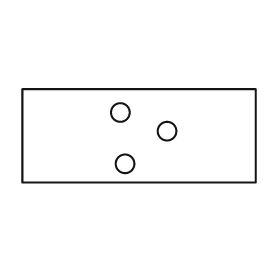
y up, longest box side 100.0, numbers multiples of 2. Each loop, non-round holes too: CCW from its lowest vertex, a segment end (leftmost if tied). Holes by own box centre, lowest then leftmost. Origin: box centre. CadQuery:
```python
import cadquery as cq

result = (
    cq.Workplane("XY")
    .moveTo(-50.0, -20.0)
    .lineTo(50.0, -20.0)
    .lineTo(50.0, 20.0)
    .lineTo(-50.0, 20.0)
    .close()
    .moveTo(-6.0, -12.0)
    .circle(4.0)
    .moveTo(12.0, 2.0)
    .circle(4.0)
    .moveTo(-8.0, 10.0)
    .circle(4.0)
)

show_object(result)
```